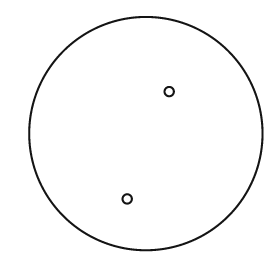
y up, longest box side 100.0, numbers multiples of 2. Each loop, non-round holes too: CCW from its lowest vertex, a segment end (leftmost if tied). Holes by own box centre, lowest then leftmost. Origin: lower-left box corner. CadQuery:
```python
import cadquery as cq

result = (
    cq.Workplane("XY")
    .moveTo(50.0, 50.0)
    .circle(50.0)
    .moveTo(42.0, 22.0)
    .circle(2.0)
    .moveTo(60.0, 68.0)
    .circle(2.0)
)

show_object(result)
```